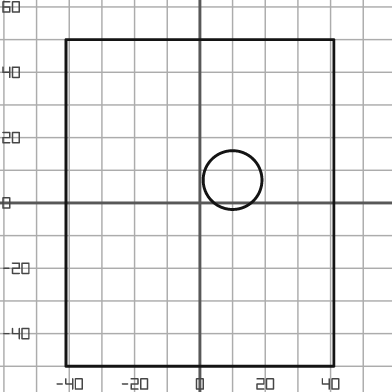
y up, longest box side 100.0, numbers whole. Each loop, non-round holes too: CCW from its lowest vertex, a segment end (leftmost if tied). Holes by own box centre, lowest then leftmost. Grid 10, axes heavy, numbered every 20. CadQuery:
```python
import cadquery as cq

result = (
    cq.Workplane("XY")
    .moveTo(-41.0, -50.0)
    .lineTo(41.0, -50.0)
    .lineTo(41.0, 50.0)
    .lineTo(-41.0, 50.0)
    .close()
    .moveTo(10.0, 7.0)
    .circle(9.0)
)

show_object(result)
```